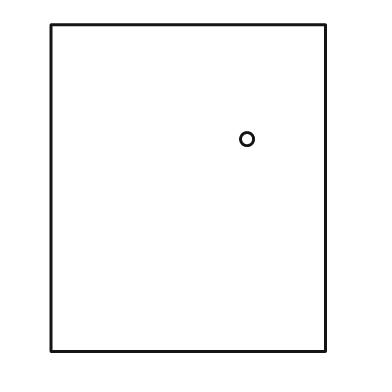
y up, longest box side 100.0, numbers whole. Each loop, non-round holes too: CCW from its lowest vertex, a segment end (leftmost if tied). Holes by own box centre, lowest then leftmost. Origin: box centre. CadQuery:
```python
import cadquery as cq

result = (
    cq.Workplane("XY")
    .moveTo(-42.0, -50.0)
    .lineTo(42.0, -50.0)
    .lineTo(42.0, 50.0)
    .lineTo(-42.0, 50.0)
    .close()
    .moveTo(18.0, 15.0)
    .circle(2.0)
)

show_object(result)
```